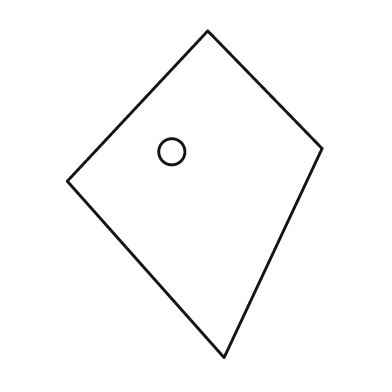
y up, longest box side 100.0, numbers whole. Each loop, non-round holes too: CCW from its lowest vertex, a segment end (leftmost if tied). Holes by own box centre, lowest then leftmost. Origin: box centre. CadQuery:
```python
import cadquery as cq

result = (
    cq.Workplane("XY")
    .moveTo(9.0, -50.0)
    .lineTo(39.0, 14.0)
    .lineTo(4.0, 50.0)
    .lineTo(-39.0, 4.0)
    .close()
    .moveTo(-7.0, 13.0)
    .circle(4.0)
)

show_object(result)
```